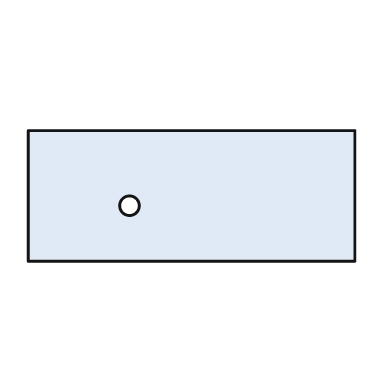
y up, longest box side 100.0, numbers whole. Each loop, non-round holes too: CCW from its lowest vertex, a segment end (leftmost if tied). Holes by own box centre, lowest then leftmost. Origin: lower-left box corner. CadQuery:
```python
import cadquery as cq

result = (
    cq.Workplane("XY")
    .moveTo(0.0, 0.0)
    .lineTo(100.0, 0.0)
    .lineTo(100.0, 40.0)
    .lineTo(0.0, 40.0)
    .close()
    .moveTo(31.0, 17.0)
    .circle(3.0)
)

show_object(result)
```